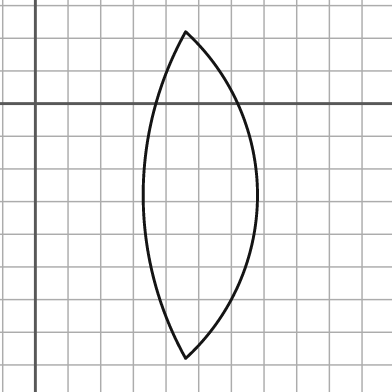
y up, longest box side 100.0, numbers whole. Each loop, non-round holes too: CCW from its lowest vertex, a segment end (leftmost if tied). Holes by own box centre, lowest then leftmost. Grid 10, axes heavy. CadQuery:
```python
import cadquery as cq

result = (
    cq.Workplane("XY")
    .moveTo(46.0, -78.0)
    .threePointArc((68.0, -28.0), (46.0, 22.0))
    .threePointArc((33.0, -28.0), (46.0, -78.0))
    .close()
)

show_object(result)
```